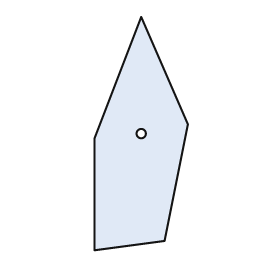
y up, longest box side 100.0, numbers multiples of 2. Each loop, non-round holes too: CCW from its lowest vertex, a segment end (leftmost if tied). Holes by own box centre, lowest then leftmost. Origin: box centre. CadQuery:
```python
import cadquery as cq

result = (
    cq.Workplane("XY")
    .moveTo(-20.0, -50.0)
    .lineTo(10.0, -46.0)
    .lineTo(20.0, 4.0)
    .lineTo(0.0, 50.0)
    .lineTo(-20.0, -2.0)
    .close()
    .moveTo(0.0, 0.0)
    .circle(2.0)
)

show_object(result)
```